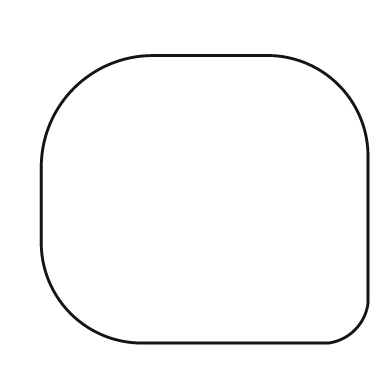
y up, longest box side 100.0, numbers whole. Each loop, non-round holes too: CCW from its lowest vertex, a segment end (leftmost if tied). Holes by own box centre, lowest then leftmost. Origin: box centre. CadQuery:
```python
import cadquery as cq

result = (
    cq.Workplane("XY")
    .moveTo(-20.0, -44.0)
    .lineTo(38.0, -44.0)
    .threePointArc((46.0, -40.0), (50.0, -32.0))
    .lineTo(50.0, 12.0)
    .threePointArc((41.0, 35.0), (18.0, 44.0))
    .lineTo(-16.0, 44.0)
    .threePointArc((-40.0, 34.0), (-50.0, 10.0))
    .lineTo(-50.0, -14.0)
    .threePointArc((-41.0, -35.0), (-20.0, -44.0))
    .close()
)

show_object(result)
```